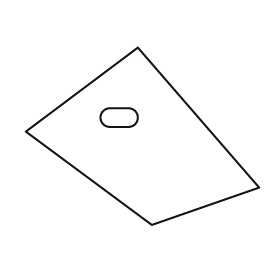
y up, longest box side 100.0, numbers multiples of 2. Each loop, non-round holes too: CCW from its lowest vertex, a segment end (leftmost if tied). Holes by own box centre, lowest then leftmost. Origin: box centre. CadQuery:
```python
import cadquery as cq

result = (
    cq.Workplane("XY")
    .moveTo(4.0, -38.0)
    .lineTo(50.0, -22.0)
    .lineTo(-2.0, 38.0)
    .lineTo(-50.0, 2.0)
    .close()
    .moveTo(-14.0, 4.0)
    .lineTo(-6.0, 4.0)
    .threePointArc((-2.0, 8.0), (-6.0, 12.0))
    .lineTo(-14.0, 12.0)
    .threePointArc((-18.0, 8.0), (-14.0, 4.0))
    .close()
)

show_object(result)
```